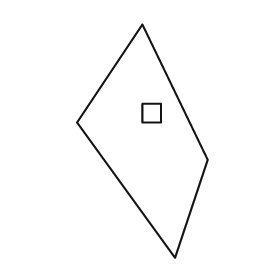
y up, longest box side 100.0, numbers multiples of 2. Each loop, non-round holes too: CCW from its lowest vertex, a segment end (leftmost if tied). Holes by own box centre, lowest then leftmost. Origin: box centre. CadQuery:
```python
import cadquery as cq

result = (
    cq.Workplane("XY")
    .moveTo(14.0, -50.0)
    .lineTo(28.0, -8.0)
    .lineTo(0.0, 50.0)
    .lineTo(-28.0, 8.0)
    .close()
    .moveTo(0.0, 8.0)
    .lineTo(8.0, 8.0)
    .lineTo(8.0, 16.0)
    .lineTo(0.0, 16.0)
    .close()
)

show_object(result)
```